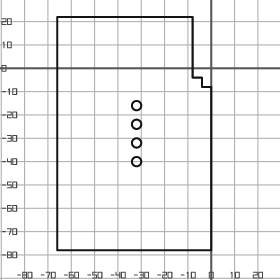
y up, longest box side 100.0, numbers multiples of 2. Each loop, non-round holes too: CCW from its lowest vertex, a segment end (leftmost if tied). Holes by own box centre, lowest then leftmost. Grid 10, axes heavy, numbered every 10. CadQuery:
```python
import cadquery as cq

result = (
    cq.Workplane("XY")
    .moveTo(-66.0, -78.0)
    .lineTo(0.0, -78.0)
    .lineTo(0.0, -8.0)
    .lineTo(-4.0, -8.0)
    .lineTo(-4.0, -4.0)
    .lineTo(-8.0, -4.0)
    .lineTo(-8.0, 22.0)
    .lineTo(-66.0, 22.0)
    .close()
    .moveTo(-32.0, -40.0)
    .circle(2.0)
    .moveTo(-32.0, -32.0)
    .circle(2.0)
    .moveTo(-32.0, -24.0)
    .circle(2.0)
    .moveTo(-32.0, -16.0)
    .circle(2.0)
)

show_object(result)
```